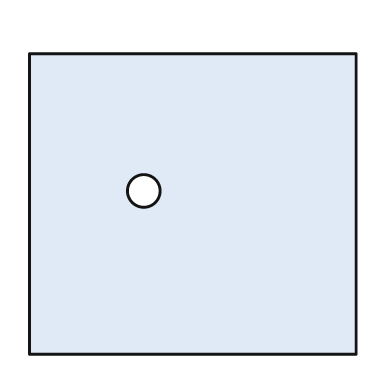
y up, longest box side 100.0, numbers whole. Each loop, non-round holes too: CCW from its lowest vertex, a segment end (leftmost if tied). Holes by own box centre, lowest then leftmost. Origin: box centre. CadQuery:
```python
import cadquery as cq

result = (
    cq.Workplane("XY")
    .moveTo(-50.0, -46.0)
    .lineTo(50.0, -46.0)
    .lineTo(50.0, 46.0)
    .lineTo(-50.0, 46.0)
    .close()
    .moveTo(-15.0, 4.0)
    .circle(5.0)
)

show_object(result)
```